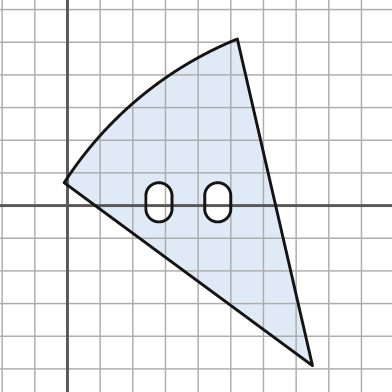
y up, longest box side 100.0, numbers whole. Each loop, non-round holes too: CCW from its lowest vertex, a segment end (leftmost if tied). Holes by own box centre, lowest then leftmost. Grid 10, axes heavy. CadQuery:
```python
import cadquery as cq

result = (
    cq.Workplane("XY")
    .moveTo(75.0, -49.0)
    .lineTo(52.0, 51.0)
    .threePointArc((22.0, 33.0), (-1.0, 7.0))
    .close()
    .moveTo(24.0, -1.0)
    .threePointArc((28.0, -5.0), (32.0, -1.0))
    .lineTo(32.0, 3.0)
    .threePointArc((28.0, 7.0), (24.0, 3.0))
    .close()
    .moveTo(42.0, -1.0)
    .threePointArc((46.0, -5.0), (50.0, -1.0))
    .lineTo(50.0, 3.0)
    .threePointArc((46.0, 7.0), (42.0, 3.0))
    .close()
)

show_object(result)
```